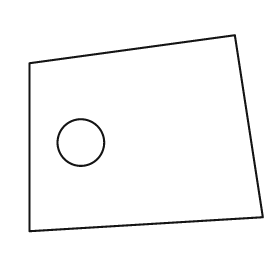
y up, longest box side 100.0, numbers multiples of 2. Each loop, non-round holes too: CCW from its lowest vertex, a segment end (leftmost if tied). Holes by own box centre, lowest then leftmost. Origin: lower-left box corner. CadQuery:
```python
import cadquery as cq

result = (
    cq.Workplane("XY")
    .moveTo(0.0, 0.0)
    .lineTo(100.0, 6.0)
    .lineTo(88.0, 84.0)
    .lineTo(0.0, 72.0)
    .close()
    .moveTo(22.0, 38.0)
    .circle(10.0)
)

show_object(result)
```